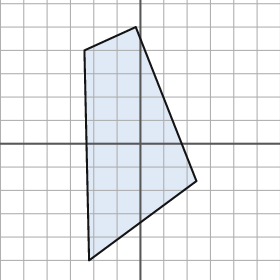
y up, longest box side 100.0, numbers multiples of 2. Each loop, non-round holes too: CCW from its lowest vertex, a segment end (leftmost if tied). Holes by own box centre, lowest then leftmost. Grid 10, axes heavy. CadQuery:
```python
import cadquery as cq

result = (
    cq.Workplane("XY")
    .moveTo(-22.0, -50.0)
    .lineTo(24.0, -16.0)
    .lineTo(-2.0, 50.0)
    .lineTo(-24.0, 40.0)
    .close()
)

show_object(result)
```